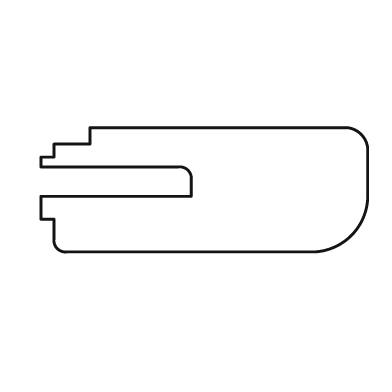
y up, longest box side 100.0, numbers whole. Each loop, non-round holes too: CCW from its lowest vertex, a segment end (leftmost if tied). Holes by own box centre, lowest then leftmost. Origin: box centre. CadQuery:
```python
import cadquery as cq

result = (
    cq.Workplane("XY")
    .moveTo(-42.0, -19.0)
    .lineTo(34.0, -19.0)
    .threePointArc((45.0, -14.0), (50.0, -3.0))
    .lineTo(50.0, 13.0)
    .threePointArc((48.0, 17.0), (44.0, 19.0))
    .lineTo(-35.0, 19.0)
    .lineTo(-35.0, 14.0)
    .lineTo(-46.0, 14.0)
    .lineTo(-46.0, 10.0)
    .lineTo(-50.0, 10.0)
    .lineTo(-50.0, 7.0)
    .lineTo(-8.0, 7.0)
    .threePointArc((-5.0, 6.0), (-4.0, 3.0))
    .lineTo(-4.0, -2.0)
    .lineTo(-50.0, -2.0)
    .lineTo(-50.0, -9.0)
    .lineTo(-46.0, -9.0)
    .lineTo(-46.0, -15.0)
    .threePointArc((-45.0, -18.0), (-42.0, -19.0))
    .close()
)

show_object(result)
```